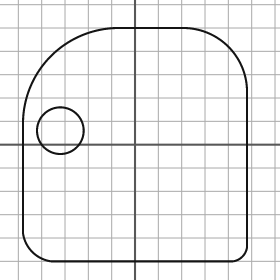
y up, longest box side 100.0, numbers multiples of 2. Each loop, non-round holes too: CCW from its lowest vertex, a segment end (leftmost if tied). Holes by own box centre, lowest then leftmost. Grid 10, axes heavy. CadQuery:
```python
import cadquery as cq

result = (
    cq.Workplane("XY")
    .moveTo(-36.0, -50.0)
    .lineTo(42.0, -50.0)
    .threePointArc((46.0, -48.0), (48.0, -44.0))
    .lineTo(48.0, 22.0)
    .threePointArc((40.0, 42.0), (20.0, 50.0))
    .lineTo(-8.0, 50.0)
    .threePointArc((-36.0, 38.0), (-48.0, 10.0))
    .lineTo(-48.0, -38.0)
    .threePointArc((-44.0, -46.0), (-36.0, -50.0))
    .close()
    .moveTo(-32.0, 6.0)
    .circle(10.0)
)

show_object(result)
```